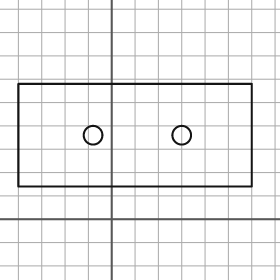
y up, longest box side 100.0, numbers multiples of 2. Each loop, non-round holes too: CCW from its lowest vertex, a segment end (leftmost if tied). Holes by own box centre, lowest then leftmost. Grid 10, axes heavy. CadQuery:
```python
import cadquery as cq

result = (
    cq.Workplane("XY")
    .moveTo(-40.0, 14.0)
    .lineTo(60.0, 14.0)
    .lineTo(60.0, 58.0)
    .lineTo(-40.0, 58.0)
    .close()
    .moveTo(-8.0, 36.0)
    .circle(4.0)
    .moveTo(30.0, 36.0)
    .circle(4.0)
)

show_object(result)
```